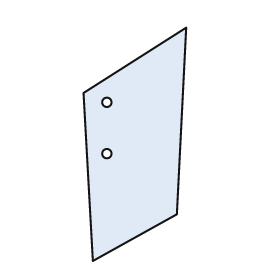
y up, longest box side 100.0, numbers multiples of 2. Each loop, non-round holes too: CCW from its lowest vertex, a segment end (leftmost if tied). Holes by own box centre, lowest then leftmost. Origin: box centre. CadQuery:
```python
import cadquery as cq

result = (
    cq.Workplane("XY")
    .moveTo(-18.0, -50.0)
    .lineTo(18.0, -30.0)
    .lineTo(22.0, 50.0)
    .lineTo(-22.0, 22.0)
    .close()
    .moveTo(-12.0, -4.0)
    .circle(2.0)
    .moveTo(-12.0, 18.0)
    .circle(2.0)
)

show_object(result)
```